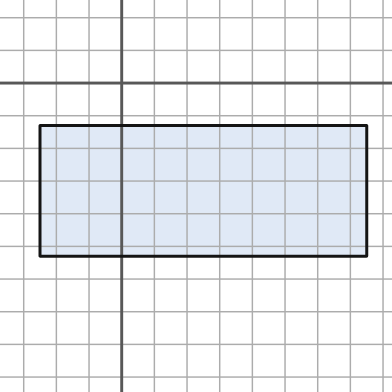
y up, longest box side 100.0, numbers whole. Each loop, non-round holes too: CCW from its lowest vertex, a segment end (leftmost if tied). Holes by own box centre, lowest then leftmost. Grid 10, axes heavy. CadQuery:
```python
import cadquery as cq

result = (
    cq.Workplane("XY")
    .moveTo(-25.0, -53.0)
    .lineTo(75.0, -53.0)
    .lineTo(75.0, -13.0)
    .lineTo(-25.0, -13.0)
    .close()
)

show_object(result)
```